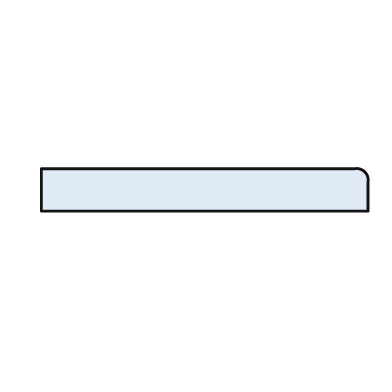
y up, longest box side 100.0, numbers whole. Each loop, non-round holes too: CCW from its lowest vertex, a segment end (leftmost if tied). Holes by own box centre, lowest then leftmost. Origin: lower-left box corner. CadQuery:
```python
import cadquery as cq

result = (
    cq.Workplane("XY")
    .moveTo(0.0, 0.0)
    .lineTo(100.0, 0.0)
    .lineTo(100.0, 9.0)
    .threePointArc((99.0, 12.0), (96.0, 13.0))
    .lineTo(0.0, 13.0)
    .close()
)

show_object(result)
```